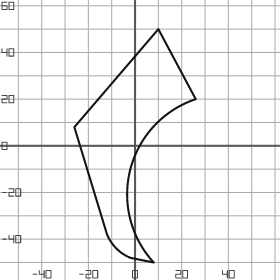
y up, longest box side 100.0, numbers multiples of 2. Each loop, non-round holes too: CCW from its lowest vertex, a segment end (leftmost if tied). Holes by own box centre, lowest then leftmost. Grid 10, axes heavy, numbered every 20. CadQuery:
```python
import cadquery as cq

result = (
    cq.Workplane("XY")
    .moveTo(8.0, -50.0)
    .threePointArc((-2.0, -10.0), (26.0, 20.0))
    .lineTo(10.0, 50.0)
    .lineTo(-26.0, 8.0)
    .lineTo(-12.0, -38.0)
    .threePointArc((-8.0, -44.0), (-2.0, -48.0))
    .close()
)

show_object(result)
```